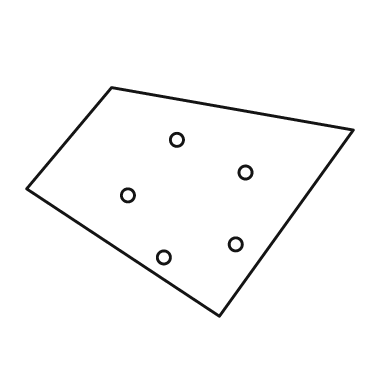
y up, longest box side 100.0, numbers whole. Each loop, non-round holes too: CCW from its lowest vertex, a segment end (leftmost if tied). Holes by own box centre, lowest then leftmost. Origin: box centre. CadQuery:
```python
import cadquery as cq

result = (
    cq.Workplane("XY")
    .moveTo(9.0, -35.0)
    .lineTo(50.0, 22.0)
    .lineTo(-24.0, 35.0)
    .lineTo(-50.0, 4.0)
    .close()
    .moveTo(-8.0, -17.0)
    .circle(2.0)
    .moveTo(14.0, -13.0)
    .circle(2.0)
    .moveTo(-19.0, 2.0)
    .circle(2.0)
    .moveTo(17.0, 9.0)
    .circle(2.0)
    .moveTo(-4.0, 19.0)
    .circle(2.0)
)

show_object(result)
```